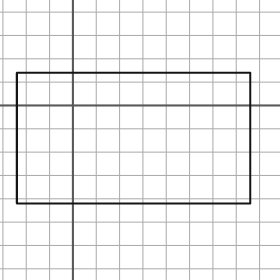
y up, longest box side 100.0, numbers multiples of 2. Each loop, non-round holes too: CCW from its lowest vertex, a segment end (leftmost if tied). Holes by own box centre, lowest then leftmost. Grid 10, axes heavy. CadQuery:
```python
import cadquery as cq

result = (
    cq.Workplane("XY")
    .moveTo(-24.0, -42.0)
    .lineTo(76.0, -42.0)
    .lineTo(76.0, 14.0)
    .lineTo(-24.0, 14.0)
    .close()
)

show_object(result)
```